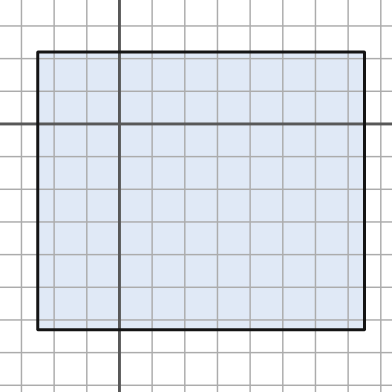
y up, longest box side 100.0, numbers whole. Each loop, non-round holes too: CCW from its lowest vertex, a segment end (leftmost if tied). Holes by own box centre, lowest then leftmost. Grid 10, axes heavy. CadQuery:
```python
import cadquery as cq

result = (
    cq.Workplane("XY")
    .moveTo(-25.0, -63.0)
    .lineTo(75.0, -63.0)
    .lineTo(75.0, 22.0)
    .lineTo(-25.0, 22.0)
    .close()
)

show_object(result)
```